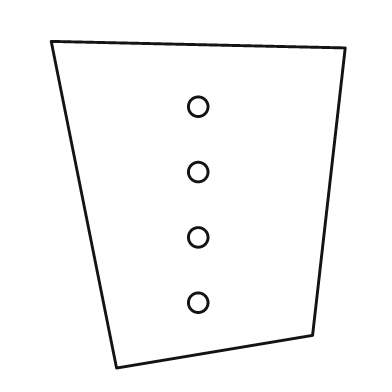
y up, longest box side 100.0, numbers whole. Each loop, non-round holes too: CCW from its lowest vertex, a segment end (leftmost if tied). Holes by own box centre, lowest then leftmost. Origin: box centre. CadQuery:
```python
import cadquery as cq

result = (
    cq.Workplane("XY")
    .moveTo(-25.0, -50.0)
    .lineTo(35.0, -40.0)
    .lineTo(45.0, 48.0)
    .lineTo(-45.0, 50.0)
    .close()
    .moveTo(0.0, -30.0)
    .circle(3.0)
    .moveTo(0.0, -10.0)
    .circle(3.0)
    .moveTo(0.0, 10.0)
    .circle(3.0)
    .moveTo(0.0, 30.0)
    .circle(3.0)
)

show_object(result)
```